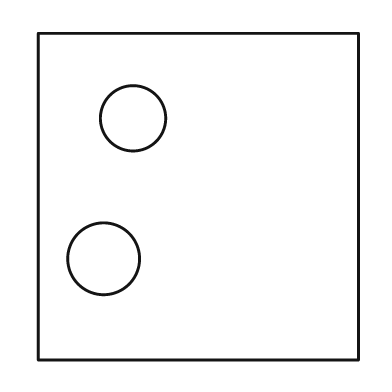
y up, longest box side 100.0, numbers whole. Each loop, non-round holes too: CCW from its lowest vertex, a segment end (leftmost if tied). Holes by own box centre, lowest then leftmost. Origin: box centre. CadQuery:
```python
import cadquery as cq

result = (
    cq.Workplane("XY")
    .moveTo(-49.0, -50.0)
    .lineTo(49.0, -50.0)
    .lineTo(49.0, 50.0)
    .lineTo(-49.0, 50.0)
    .close()
    .moveTo(-29.0, -19.0)
    .circle(11.0)
    .moveTo(-20.0, 24.0)
    .circle(10.0)
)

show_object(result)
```